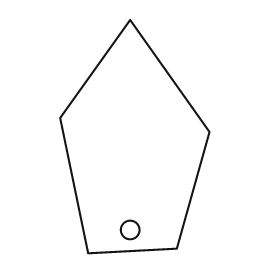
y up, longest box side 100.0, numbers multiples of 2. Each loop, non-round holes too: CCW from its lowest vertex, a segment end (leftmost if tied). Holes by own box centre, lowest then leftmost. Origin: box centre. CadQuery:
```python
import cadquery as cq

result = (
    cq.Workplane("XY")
    .moveTo(-20.0, -50.0)
    .lineTo(18.0, -48.0)
    .lineTo(32.0, 2.0)
    .lineTo(-2.0, 50.0)
    .lineTo(-32.0, 8.0)
    .close()
    .moveTo(-2.0, -40.0)
    .circle(4.0)
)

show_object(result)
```